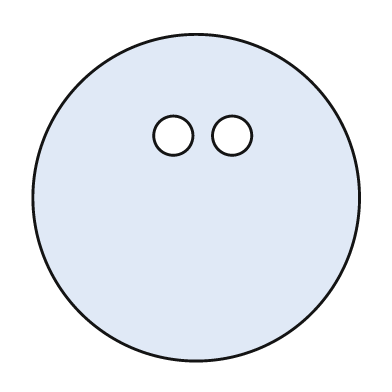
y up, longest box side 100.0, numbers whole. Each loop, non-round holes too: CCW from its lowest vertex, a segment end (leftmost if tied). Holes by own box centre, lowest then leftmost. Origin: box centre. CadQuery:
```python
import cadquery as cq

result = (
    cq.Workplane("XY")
    .moveTo(0.0, 0.0)
    .circle(50.0)
    .moveTo(-7.0, 19.0)
    .circle(6.0)
    .moveTo(11.0, 19.0)
    .circle(6.0)
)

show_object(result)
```